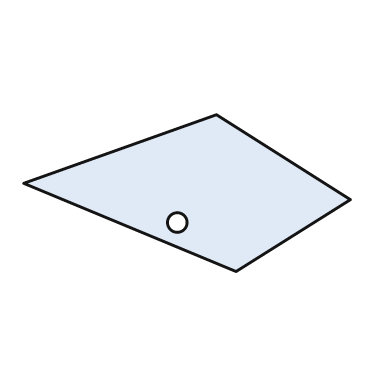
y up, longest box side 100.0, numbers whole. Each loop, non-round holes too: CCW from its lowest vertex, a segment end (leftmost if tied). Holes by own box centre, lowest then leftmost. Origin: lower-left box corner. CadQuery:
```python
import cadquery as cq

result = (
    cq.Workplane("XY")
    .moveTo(65.0, 0.0)
    .lineTo(100.0, 22.0)
    .lineTo(59.0, 48.0)
    .lineTo(0.0, 27.0)
    .close()
    .moveTo(47.0, 15.0)
    .circle(3.0)
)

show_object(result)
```